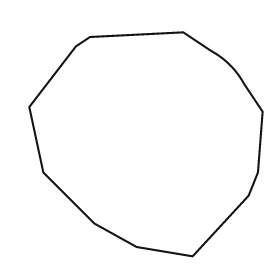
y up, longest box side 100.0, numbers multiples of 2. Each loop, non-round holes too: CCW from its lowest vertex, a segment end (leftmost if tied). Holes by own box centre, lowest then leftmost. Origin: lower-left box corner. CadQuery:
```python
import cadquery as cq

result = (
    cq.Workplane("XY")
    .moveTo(70.0, 0.0)
    .lineTo(94.0, 26.0)
    .lineTo(98.0, 36.0)
    .lineTo(100.0, 62.0)
    .lineTo(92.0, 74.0)
    .threePointArc((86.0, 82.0), (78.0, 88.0))
    .lineTo(66.0, 96.0)
    .lineTo(26.0, 94.0)
    .lineTo(20.0, 90.0)
    .lineTo(0.0, 64.0)
    .lineTo(6.0, 36.0)
    .lineTo(28.0, 14.0)
    .lineTo(46.0, 4.0)
    .close()
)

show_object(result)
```